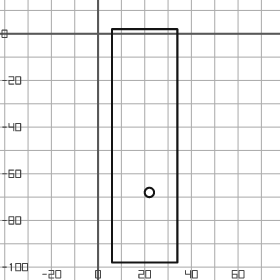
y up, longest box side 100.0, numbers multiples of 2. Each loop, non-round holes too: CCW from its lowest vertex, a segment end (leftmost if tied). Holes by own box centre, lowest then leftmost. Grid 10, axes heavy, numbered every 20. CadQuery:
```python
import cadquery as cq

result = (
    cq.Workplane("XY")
    .moveTo(6.0, -98.0)
    .lineTo(34.0, -98.0)
    .lineTo(34.0, 2.0)
    .lineTo(6.0, 2.0)
    .close()
    .moveTo(22.0, -68.0)
    .circle(2.0)
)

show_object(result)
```